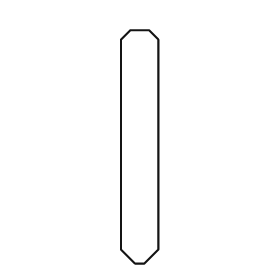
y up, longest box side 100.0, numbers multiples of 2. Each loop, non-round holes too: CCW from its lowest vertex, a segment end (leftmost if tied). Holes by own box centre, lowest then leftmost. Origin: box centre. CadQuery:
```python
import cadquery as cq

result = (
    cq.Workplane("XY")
    .moveTo(-2.0, -50.0)
    .lineTo(2.0, -50.0)
    .lineTo(8.0, -44.0)
    .lineTo(8.0, 46.0)
    .lineTo(4.0, 50.0)
    .lineTo(-4.0, 50.0)
    .lineTo(-8.0, 46.0)
    .lineTo(-8.0, -44.0)
    .close()
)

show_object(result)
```